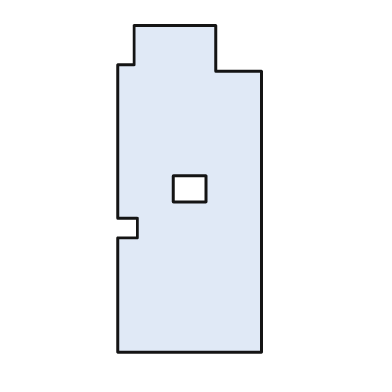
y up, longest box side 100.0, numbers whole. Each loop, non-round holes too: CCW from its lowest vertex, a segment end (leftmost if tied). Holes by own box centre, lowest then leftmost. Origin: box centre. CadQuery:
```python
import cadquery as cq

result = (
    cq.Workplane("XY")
    .moveTo(-22.0, -50.0)
    .lineTo(22.0, -50.0)
    .lineTo(22.0, 36.0)
    .lineTo(8.0, 36.0)
    .lineTo(8.0, 50.0)
    .lineTo(-17.0, 50.0)
    .lineTo(-17.0, 38.0)
    .lineTo(-22.0, 38.0)
    .lineTo(-22.0, -9.0)
    .lineTo(-16.0, -9.0)
    .lineTo(-16.0, -15.0)
    .lineTo(-22.0, -15.0)
    .close()
    .moveTo(-5.0, -4.0)
    .lineTo(5.0, -4.0)
    .lineTo(5.0, 4.0)
    .lineTo(-5.0, 4.0)
    .close()
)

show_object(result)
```